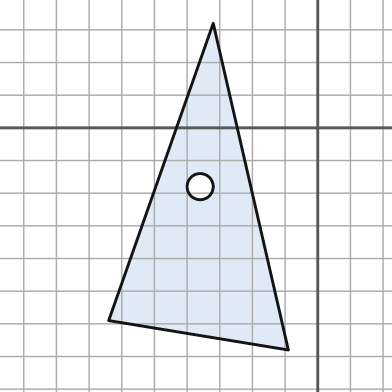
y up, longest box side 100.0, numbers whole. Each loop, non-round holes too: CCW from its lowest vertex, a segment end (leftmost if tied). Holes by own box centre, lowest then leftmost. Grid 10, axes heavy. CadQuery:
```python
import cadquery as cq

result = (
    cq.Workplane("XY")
    .moveTo(-9.0, -68.0)
    .lineTo(-32.0, 32.0)
    .lineTo(-64.0, -59.0)
    .close()
    .moveTo(-36.0, -18.0)
    .circle(4.0)
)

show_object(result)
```